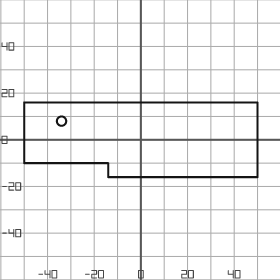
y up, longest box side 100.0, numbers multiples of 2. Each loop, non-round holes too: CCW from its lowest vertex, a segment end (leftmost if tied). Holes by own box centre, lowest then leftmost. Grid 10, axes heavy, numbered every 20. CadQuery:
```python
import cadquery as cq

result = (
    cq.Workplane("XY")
    .moveTo(-14.0, -16.0)
    .lineTo(50.0, -16.0)
    .lineTo(50.0, 16.0)
    .lineTo(-50.0, 16.0)
    .lineTo(-50.0, -10.0)
    .lineTo(-14.0, -10.0)
    .close()
    .moveTo(-34.0, 8.0)
    .circle(2.0)
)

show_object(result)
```